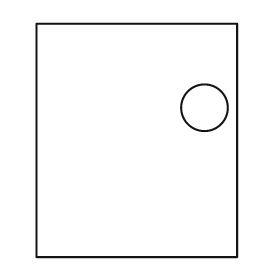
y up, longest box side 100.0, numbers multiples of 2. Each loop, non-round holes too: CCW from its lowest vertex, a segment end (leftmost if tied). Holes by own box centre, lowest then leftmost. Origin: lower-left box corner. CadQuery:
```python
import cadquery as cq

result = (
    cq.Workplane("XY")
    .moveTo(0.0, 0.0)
    .lineTo(86.0, 0.0)
    .lineTo(86.0, 100.0)
    .lineTo(0.0, 100.0)
    .close()
    .moveTo(72.0, 64.0)
    .circle(10.0)
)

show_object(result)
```